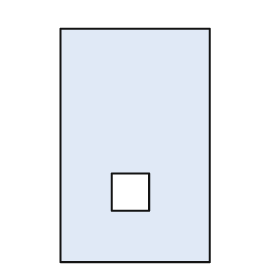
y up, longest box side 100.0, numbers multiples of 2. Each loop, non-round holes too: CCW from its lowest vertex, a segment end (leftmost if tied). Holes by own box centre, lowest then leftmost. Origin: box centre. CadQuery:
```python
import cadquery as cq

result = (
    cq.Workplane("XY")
    .moveTo(-32.0, -50.0)
    .lineTo(32.0, -50.0)
    .lineTo(32.0, 50.0)
    .lineTo(-32.0, 50.0)
    .close()
    .moveTo(-10.0, -28.0)
    .lineTo(6.0, -28.0)
    .lineTo(6.0, -12.0)
    .lineTo(-10.0, -12.0)
    .close()
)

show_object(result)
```